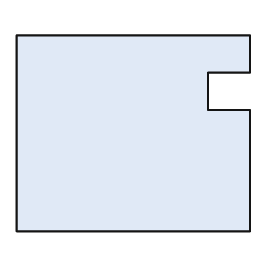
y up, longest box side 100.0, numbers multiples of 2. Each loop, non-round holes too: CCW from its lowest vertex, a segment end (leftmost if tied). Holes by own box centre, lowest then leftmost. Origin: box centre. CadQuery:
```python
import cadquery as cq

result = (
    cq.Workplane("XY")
    .moveTo(-50.0, -42.0)
    .lineTo(50.0, -42.0)
    .lineTo(50.0, 10.0)
    .lineTo(32.0, 10.0)
    .lineTo(32.0, 26.0)
    .lineTo(50.0, 26.0)
    .lineTo(50.0, 42.0)
    .lineTo(-50.0, 42.0)
    .close()
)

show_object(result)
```